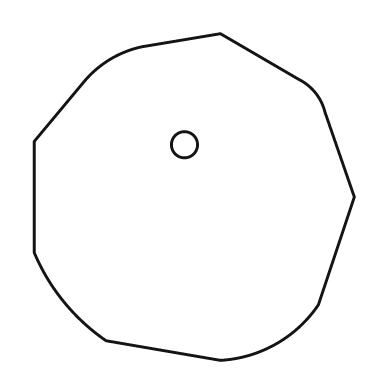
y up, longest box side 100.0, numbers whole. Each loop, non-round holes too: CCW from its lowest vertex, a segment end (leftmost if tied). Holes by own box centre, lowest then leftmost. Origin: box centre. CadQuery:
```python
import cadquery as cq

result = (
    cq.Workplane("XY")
    .moveTo(8.0, -50.0)
    .threePointArc((25.0, -45.0), (38.0, -33.0))
    .lineTo(49.0, 0.0)
    .lineTo(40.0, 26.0)
    .threePointArc((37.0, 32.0), (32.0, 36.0))
    .lineTo(8.0, 50.0)
    .lineTo(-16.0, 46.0)
    .threePointArc((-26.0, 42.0), (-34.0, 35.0))
    .lineTo(-49.0, 17.0)
    .lineTo(-49.0, -17.0)
    .threePointArc((-40.0, -32.0), (-27.0, -44.0))
    .close()
    .moveTo(-3.0, 16.0)
    .circle(4.0)
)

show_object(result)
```